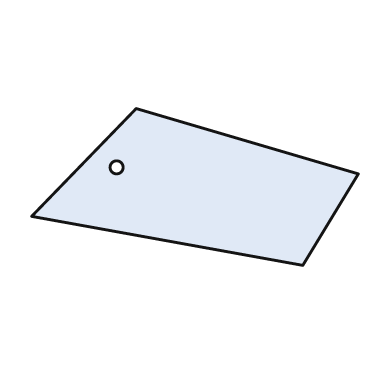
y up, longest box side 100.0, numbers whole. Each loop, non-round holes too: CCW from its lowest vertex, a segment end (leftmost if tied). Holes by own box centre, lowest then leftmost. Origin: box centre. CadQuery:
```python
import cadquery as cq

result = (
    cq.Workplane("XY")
    .moveTo(33.0, -24.0)
    .lineTo(50.0, 4.0)
    .lineTo(-18.0, 24.0)
    .lineTo(-50.0, -9.0)
    .close()
    .moveTo(-24.0, 6.0)
    .circle(2.0)
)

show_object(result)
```